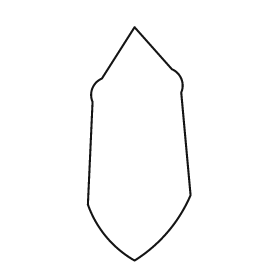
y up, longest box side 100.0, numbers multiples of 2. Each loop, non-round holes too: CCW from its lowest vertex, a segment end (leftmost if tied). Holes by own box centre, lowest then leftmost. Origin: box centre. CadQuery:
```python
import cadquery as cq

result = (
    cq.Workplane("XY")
    .moveTo(-2.0, -50.0)
    .threePointArc((12.0, -38.0), (22.0, -22.0))
    .lineTo(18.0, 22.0)
    .threePointArc((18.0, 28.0), (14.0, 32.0))
    .lineTo(-2.0, 50.0)
    .lineTo(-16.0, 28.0)
    .threePointArc((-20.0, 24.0), (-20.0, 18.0))
    .lineTo(-22.0, -26.0)
    .threePointArc((-14.0, -40.0), (-2.0, -50.0))
    .close()
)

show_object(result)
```